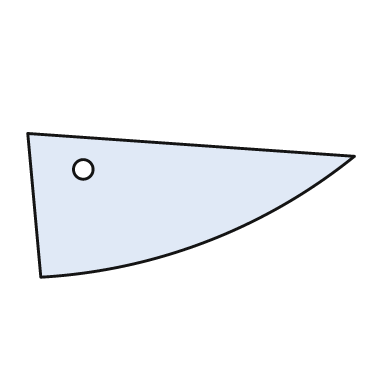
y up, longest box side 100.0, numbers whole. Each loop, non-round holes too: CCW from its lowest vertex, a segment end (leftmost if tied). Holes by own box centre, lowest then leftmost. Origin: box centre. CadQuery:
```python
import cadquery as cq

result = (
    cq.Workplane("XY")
    .moveTo(-46.0, -22.0)
    .threePointArc((5.0, -11.0), (50.0, 15.0))
    .lineTo(-50.0, 22.0)
    .close()
    .moveTo(-33.0, 11.0)
    .circle(3.0)
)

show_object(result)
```